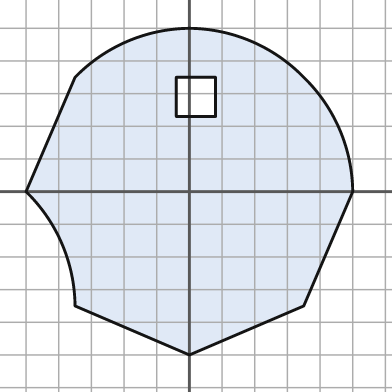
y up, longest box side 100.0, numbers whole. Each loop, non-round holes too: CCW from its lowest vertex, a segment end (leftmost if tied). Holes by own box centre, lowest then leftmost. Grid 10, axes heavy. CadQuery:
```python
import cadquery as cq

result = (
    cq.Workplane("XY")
    .moveTo(0.0, -50.0)
    .lineTo(35.0, -35.0)
    .lineTo(50.0, 0.0)
    .threePointArc((46.0, 19.0), (35.0, 35.0))
    .threePointArc((19.0, 46.0), (0.0, 50.0))
    .threePointArc((-19.0, 46.0), (-35.0, 35.0))
    .lineTo(-50.0, 0.0)
    .threePointArc((-39.0, -16.0), (-35.0, -35.0))
    .close()
    .moveTo(-4.0, 23.0)
    .lineTo(8.0, 23.0)
    .lineTo(8.0, 35.0)
    .lineTo(-4.0, 35.0)
    .close()
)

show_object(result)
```